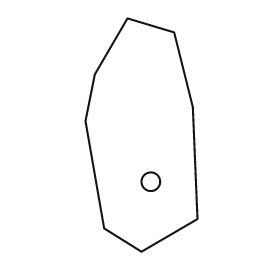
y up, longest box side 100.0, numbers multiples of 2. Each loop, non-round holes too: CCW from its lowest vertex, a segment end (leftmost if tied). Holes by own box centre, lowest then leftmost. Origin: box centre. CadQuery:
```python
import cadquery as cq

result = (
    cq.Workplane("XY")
    .moveTo(0.0, -50.0)
    .lineTo(24.0, -36.0)
    .lineTo(22.0, 12.0)
    .lineTo(14.0, 44.0)
    .lineTo(-6.0, 50.0)
    .lineTo(-20.0, 26.0)
    .lineTo(-24.0, 6.0)
    .lineTo(-16.0, -40.0)
    .close()
    .moveTo(4.0, -20.0)
    .circle(4.0)
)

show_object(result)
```